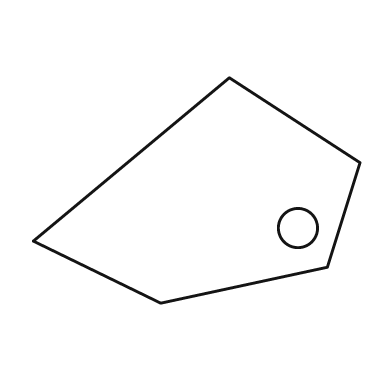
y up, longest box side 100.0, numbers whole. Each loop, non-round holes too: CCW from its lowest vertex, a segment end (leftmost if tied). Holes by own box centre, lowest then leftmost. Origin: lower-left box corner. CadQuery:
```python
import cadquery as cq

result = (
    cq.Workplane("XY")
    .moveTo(39.0, 0.0)
    .lineTo(90.0, 11.0)
    .lineTo(100.0, 43.0)
    .lineTo(60.0, 69.0)
    .lineTo(0.0, 19.0)
    .close()
    .moveTo(81.0, 23.0)
    .circle(6.0)
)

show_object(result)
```